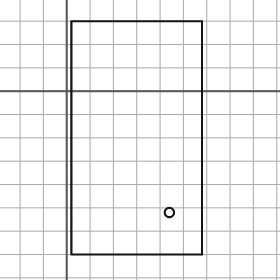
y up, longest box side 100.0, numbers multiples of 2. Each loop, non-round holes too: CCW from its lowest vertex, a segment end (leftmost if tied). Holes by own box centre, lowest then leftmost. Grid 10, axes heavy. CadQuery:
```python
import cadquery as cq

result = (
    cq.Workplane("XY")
    .moveTo(2.0, -70.0)
    .lineTo(58.0, -70.0)
    .lineTo(58.0, 30.0)
    .lineTo(2.0, 30.0)
    .close()
    .moveTo(44.0, -52.0)
    .circle(2.0)
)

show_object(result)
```